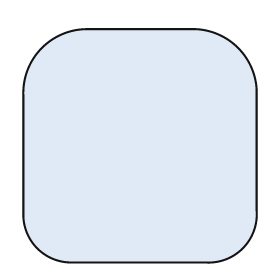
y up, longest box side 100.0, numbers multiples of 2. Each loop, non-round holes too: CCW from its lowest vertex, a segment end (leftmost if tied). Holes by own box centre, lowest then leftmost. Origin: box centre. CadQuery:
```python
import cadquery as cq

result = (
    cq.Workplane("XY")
    .moveTo(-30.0, -50.0)
    .lineTo(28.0, -50.0)
    .threePointArc((44.0, -44.0), (50.0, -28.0))
    .lineTo(50.0, 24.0)
    .threePointArc((42.0, 42.0), (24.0, 50.0))
    .lineTo(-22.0, 50.0)
    .threePointArc((-42.0, 42.0), (-50.0, 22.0))
    .lineTo(-50.0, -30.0)
    .threePointArc((-44.0, -44.0), (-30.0, -50.0))
    .close()
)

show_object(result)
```